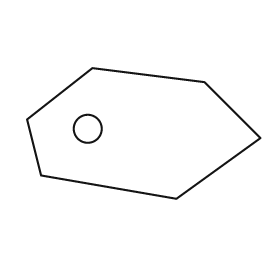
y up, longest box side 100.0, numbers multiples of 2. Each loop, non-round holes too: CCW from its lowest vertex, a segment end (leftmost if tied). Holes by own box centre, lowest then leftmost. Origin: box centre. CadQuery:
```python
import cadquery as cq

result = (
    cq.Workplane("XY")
    .moveTo(14.0, -28.0)
    .lineTo(50.0, -2.0)
    .lineTo(26.0, 22.0)
    .lineTo(-22.0, 28.0)
    .lineTo(-50.0, 6.0)
    .lineTo(-44.0, -18.0)
    .close()
    .moveTo(-24.0, 2.0)
    .circle(6.0)
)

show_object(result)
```